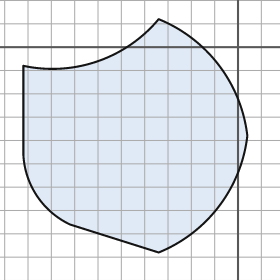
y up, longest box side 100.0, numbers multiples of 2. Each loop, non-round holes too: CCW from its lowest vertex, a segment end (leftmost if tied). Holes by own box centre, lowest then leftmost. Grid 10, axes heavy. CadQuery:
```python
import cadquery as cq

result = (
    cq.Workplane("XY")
    .moveTo(-34.0, -88.0)
    .threePointArc((-8.0, -68.0), (4.0, -38.0))
    .threePointArc((-8.0, -8.0), (-34.0, 12.0))
    .threePointArc((-60.0, -6.0), (-92.0, -8.0))
    .lineTo(-92.0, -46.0)
    .threePointArc((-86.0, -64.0), (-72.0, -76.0))
    .close()
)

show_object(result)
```